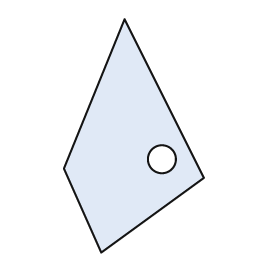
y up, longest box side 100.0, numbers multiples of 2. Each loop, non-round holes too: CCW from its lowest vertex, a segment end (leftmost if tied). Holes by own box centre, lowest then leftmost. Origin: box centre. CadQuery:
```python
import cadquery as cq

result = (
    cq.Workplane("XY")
    .moveTo(-14.0, -50.0)
    .lineTo(30.0, -18.0)
    .lineTo(-4.0, 50.0)
    .lineTo(-30.0, -14.0)
    .close()
    .moveTo(12.0, -10.0)
    .circle(6.0)
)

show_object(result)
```